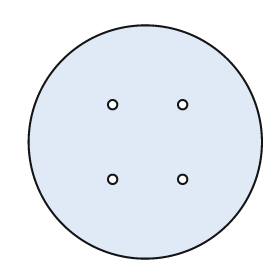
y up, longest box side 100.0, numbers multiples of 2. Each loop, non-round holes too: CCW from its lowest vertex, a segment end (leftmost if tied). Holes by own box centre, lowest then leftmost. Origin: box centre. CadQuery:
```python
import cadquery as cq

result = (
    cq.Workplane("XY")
    .moveTo(0.0, 0.0)
    .circle(50.0)
    .moveTo(-14.0, -16.0)
    .circle(2.0)
    .moveTo(16.0, -16.0)
    .circle(2.0)
    .moveTo(-14.0, 16.0)
    .circle(2.0)
    .moveTo(16.0, 16.0)
    .circle(2.0)
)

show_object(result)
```